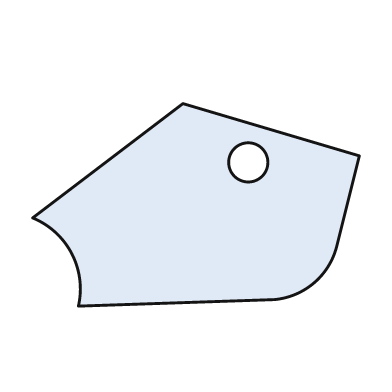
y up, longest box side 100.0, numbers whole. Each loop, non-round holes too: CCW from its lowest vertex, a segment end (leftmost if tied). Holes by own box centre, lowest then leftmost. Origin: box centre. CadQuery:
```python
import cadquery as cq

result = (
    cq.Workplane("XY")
    .moveTo(-36.0, -31.0)
    .lineTo(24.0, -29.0)
    .threePointArc((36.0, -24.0), (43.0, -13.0))
    .lineTo(50.0, 15.0)
    .lineTo(-4.0, 31.0)
    .lineTo(-50.0, -4.0)
    .threePointArc((-38.0, -15.0), (-36.0, -31.0))
    .close()
    .moveTo(16.0, 13.0)
    .circle(6.0)
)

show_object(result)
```